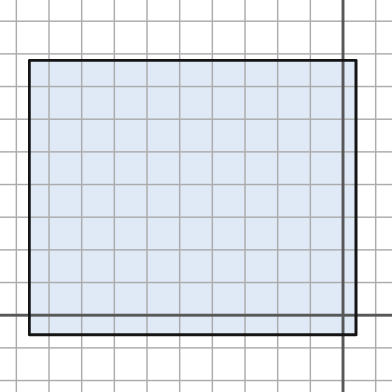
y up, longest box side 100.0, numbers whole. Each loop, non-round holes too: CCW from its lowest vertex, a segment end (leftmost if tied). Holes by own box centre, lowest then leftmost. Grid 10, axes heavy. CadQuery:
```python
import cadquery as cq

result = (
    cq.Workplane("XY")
    .moveTo(-96.0, -6.0)
    .lineTo(4.0, -6.0)
    .lineTo(4.0, 78.0)
    .lineTo(-96.0, 78.0)
    .close()
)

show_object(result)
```